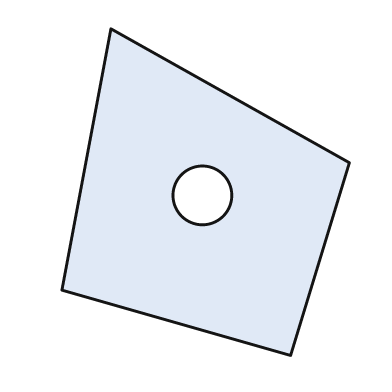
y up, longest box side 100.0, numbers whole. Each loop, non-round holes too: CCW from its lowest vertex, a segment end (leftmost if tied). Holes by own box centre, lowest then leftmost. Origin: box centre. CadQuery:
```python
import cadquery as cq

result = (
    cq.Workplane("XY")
    .moveTo(26.0, -50.0)
    .lineTo(44.0, 9.0)
    .lineTo(-29.0, 50.0)
    .lineTo(-44.0, -30.0)
    .close()
    .moveTo(-1.0, -1.0)
    .circle(9.0)
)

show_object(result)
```